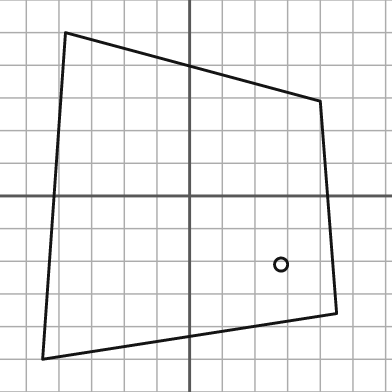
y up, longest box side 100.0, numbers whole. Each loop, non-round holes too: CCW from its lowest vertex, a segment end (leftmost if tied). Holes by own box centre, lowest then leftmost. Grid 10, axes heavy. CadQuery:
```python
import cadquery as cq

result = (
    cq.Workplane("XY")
    .moveTo(-45.0, -50.0)
    .lineTo(45.0, -36.0)
    .lineTo(40.0, 29.0)
    .lineTo(-38.0, 50.0)
    .close()
    .moveTo(28.0, -21.0)
    .circle(2.0)
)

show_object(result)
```